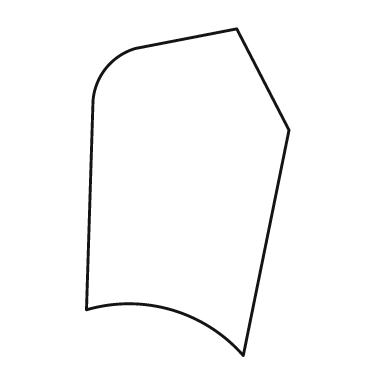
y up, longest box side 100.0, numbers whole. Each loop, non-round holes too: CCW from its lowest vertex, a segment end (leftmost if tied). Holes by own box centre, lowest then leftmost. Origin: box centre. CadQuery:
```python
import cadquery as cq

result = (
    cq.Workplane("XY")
    .moveTo(17.0, -50.0)
    .lineTo(31.0, 19.0)
    .lineTo(15.0, 50.0)
    .lineTo(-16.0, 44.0)
    .threePointArc((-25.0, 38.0), (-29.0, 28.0))
    .lineTo(-31.0, -36.0)
    .threePointArc((-5.0, -36.0), (17.0, -50.0))
    .close()
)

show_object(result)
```